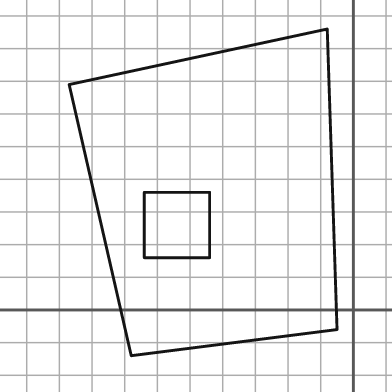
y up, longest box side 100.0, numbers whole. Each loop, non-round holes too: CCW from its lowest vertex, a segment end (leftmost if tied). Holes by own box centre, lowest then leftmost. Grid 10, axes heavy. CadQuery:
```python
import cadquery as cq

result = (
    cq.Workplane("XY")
    .moveTo(-68.0, -14.0)
    .lineTo(-5.0, -6.0)
    .lineTo(-8.0, 86.0)
    .lineTo(-87.0, 69.0)
    .close()
    .moveTo(-64.0, 16.0)
    .lineTo(-44.0, 16.0)
    .lineTo(-44.0, 36.0)
    .lineTo(-64.0, 36.0)
    .close()
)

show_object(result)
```